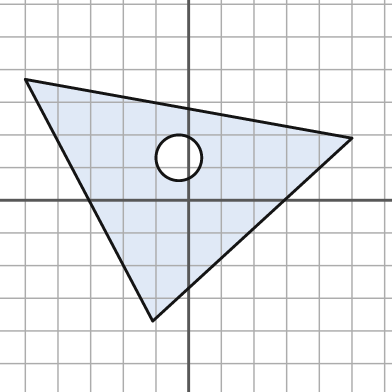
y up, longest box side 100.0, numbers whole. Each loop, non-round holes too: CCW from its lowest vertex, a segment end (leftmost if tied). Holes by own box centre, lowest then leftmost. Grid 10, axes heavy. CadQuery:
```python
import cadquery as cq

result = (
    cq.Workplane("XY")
    .moveTo(-11.0, -37.0)
    .lineTo(50.0, 19.0)
    .lineTo(-50.0, 37.0)
    .close()
    .moveTo(-3.0, 13.0)
    .circle(7.0)
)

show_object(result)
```